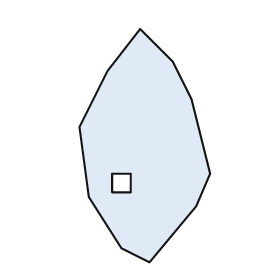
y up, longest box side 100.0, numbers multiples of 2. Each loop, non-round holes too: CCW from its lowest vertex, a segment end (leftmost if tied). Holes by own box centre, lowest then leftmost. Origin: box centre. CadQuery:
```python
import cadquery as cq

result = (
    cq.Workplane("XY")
    .moveTo(2.0, -50.0)
    .lineTo(22.0, -26.0)
    .lineTo(28.0, -12.0)
    .lineTo(20.0, 20.0)
    .lineTo(12.0, 36.0)
    .lineTo(-2.0, 50.0)
    .lineTo(-16.0, 32.0)
    .lineTo(-28.0, 8.0)
    .lineTo(-24.0, -22.0)
    .lineTo(-10.0, -44.0)
    .close()
    .moveTo(-14.0, -20.0)
    .lineTo(-6.0, -20.0)
    .lineTo(-6.0, -12.0)
    .lineTo(-14.0, -12.0)
    .close()
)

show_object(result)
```